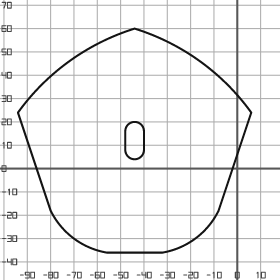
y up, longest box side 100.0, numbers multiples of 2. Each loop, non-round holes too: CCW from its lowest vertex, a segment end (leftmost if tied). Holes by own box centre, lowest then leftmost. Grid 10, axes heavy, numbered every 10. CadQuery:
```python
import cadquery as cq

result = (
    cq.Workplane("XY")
    .moveTo(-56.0, -36.0)
    .lineTo(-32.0, -36.0)
    .threePointArc((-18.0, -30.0), (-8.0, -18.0))
    .lineTo(6.0, 24.0)
    .threePointArc((-16.0, 46.0), (-44.0, 60.0))
    .threePointArc((-72.0, 46.0), (-94.0, 24.0))
    .lineTo(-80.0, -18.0)
    .threePointArc((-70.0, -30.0), (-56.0, -36.0))
    .close()
    .moveTo(-48.0, 8.0)
    .threePointArc((-44.0, 4.0), (-40.0, 8.0))
    .lineTo(-40.0, 16.0)
    .threePointArc((-44.0, 20.0), (-48.0, 16.0))
    .close()
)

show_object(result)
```